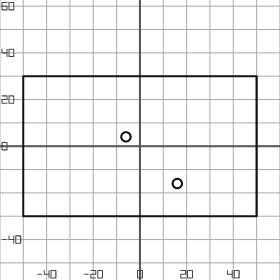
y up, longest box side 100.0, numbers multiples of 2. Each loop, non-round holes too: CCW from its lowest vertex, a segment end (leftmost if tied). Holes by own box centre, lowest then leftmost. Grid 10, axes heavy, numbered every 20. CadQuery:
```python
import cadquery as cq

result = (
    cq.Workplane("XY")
    .moveTo(-50.0, -30.0)
    .lineTo(50.0, -30.0)
    .lineTo(50.0, 30.0)
    .lineTo(-50.0, 30.0)
    .close()
    .moveTo(16.0, -16.0)
    .circle(2.0)
    .moveTo(-6.0, 4.0)
    .circle(2.0)
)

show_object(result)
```